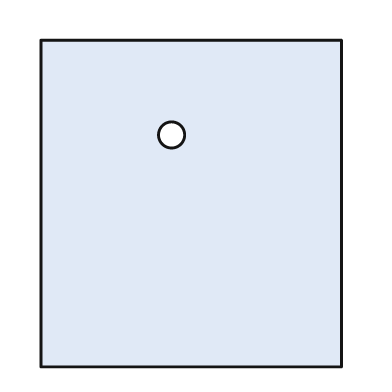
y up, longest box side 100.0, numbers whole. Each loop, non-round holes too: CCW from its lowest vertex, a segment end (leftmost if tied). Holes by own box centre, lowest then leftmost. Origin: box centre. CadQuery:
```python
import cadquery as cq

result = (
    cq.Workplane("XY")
    .moveTo(-46.0, -50.0)
    .lineTo(46.0, -50.0)
    .lineTo(46.0, 50.0)
    .lineTo(-46.0, 50.0)
    .close()
    .moveTo(-6.0, 21.0)
    .circle(4.0)
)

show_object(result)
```